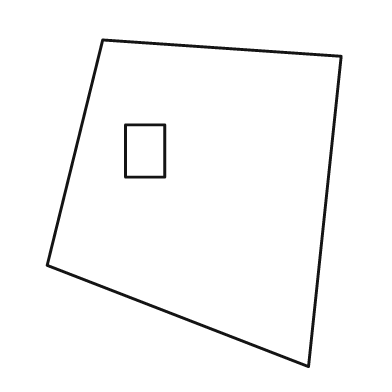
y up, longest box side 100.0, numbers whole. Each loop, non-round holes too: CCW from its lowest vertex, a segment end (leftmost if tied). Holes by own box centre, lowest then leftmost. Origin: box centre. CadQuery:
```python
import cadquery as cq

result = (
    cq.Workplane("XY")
    .moveTo(35.0, -50.0)
    .lineTo(45.0, 45.0)
    .lineTo(-28.0, 50.0)
    .lineTo(-45.0, -19.0)
    .close()
    .moveTo(-21.0, 8.0)
    .lineTo(-9.0, 8.0)
    .lineTo(-9.0, 24.0)
    .lineTo(-21.0, 24.0)
    .close()
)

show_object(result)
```